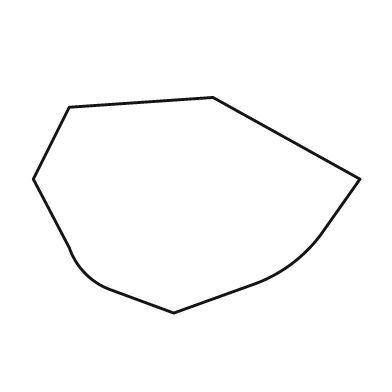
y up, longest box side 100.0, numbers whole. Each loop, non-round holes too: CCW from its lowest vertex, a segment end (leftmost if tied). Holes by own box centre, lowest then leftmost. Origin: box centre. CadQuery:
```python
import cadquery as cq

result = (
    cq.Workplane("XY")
    .moveTo(-7.0, -33.0)
    .lineTo(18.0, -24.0)
    .threePointArc((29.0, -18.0), (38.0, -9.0))
    .lineTo(50.0, 8.0)
    .lineTo(5.0, 33.0)
    .lineTo(-39.0, 30.0)
    .lineTo(-50.0, 8.0)
    .lineTo(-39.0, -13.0)
    .threePointArc((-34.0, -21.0), (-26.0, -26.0))
    .close()
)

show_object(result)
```